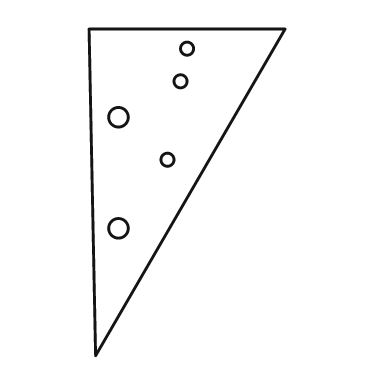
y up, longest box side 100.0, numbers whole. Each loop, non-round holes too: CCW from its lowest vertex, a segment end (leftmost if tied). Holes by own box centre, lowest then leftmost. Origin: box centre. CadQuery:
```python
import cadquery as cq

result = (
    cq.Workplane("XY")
    .moveTo(-28.0, -50.0)
    .lineTo(30.0, 50.0)
    .lineTo(-30.0, 50.0)
    .close()
    .moveTo(-21.0, -11.0)
    .circle(3.0)
    .moveTo(-6.0, 10.0)
    .circle(2.0)
    .moveTo(-21.0, 23.0)
    .circle(3.0)
    .moveTo(-2.0, 34.0)
    .circle(2.0)
    .moveTo(0.0, 44.0)
    .circle(2.0)
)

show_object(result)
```